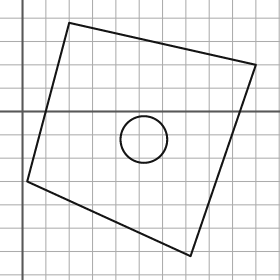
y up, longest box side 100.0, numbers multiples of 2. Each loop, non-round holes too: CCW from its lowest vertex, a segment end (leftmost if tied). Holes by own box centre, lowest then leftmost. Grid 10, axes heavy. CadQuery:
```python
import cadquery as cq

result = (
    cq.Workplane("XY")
    .moveTo(72.0, -62.0)
    .lineTo(100.0, 20.0)
    .lineTo(20.0, 38.0)
    .lineTo(2.0, -30.0)
    .close()
    .moveTo(52.0, -12.0)
    .circle(10.0)
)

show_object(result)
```